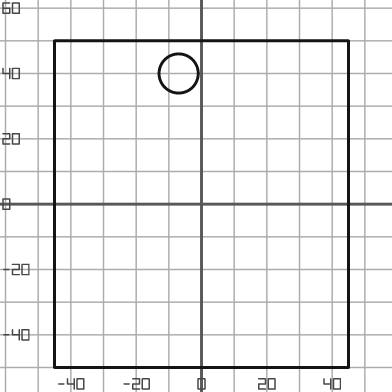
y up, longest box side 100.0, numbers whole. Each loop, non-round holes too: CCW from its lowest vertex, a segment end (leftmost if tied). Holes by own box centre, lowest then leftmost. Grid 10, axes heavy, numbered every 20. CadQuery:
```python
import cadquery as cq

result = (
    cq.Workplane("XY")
    .moveTo(-45.0, -50.0)
    .lineTo(45.0, -50.0)
    .lineTo(45.0, 50.0)
    .lineTo(-45.0, 50.0)
    .close()
    .moveTo(-7.0, 40.0)
    .circle(6.0)
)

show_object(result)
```